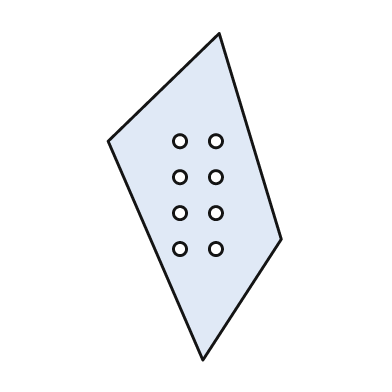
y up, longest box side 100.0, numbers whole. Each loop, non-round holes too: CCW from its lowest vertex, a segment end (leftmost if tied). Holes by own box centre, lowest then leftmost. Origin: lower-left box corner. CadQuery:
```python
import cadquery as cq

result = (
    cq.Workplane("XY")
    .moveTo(29.0, 0.0)
    .lineTo(53.0, 37.0)
    .lineTo(34.0, 100.0)
    .lineTo(0.0, 67.0)
    .close()
    .moveTo(22.0, 34.0)
    .circle(2.0)
    .moveTo(33.0, 34.0)
    .circle(2.0)
    .moveTo(22.0, 45.0)
    .circle(2.0)
    .moveTo(33.0, 45.0)
    .circle(2.0)
    .moveTo(22.0, 56.0)
    .circle(2.0)
    .moveTo(33.0, 56.0)
    .circle(2.0)
    .moveTo(22.0, 67.0)
    .circle(2.0)
    .moveTo(33.0, 67.0)
    .circle(2.0)
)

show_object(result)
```